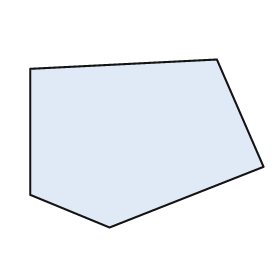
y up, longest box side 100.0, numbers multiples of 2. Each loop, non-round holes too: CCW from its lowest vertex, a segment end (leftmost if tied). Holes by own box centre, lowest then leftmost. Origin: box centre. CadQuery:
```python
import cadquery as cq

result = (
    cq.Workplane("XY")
    .moveTo(-16.0, -36.0)
    .lineTo(50.0, -10.0)
    .lineTo(30.0, 36.0)
    .lineTo(-50.0, 32.0)
    .lineTo(-50.0, -22.0)
    .close()
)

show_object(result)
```